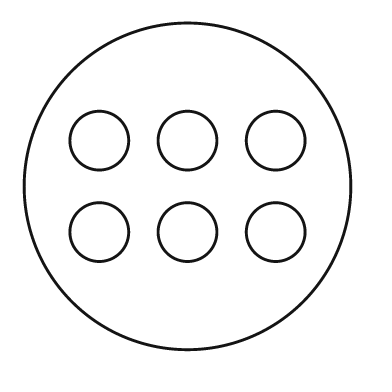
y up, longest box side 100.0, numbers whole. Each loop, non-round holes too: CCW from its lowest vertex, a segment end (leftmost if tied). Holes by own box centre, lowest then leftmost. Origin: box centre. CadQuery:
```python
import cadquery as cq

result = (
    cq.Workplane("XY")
    .moveTo(0.0, 0.0)
    .circle(50.0)
    .moveTo(-27.0, -14.0)
    .circle(9.0)
    .moveTo(0.0, -14.0)
    .circle(9.0)
    .moveTo(27.0, -14.0)
    .circle(9.0)
    .moveTo(-27.0, 14.0)
    .circle(9.0)
    .moveTo(0.0, 14.0)
    .circle(9.0)
    .moveTo(27.0, 14.0)
    .circle(9.0)
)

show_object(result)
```